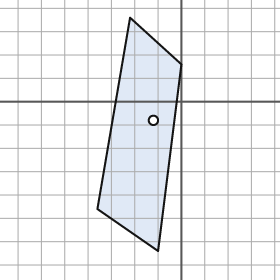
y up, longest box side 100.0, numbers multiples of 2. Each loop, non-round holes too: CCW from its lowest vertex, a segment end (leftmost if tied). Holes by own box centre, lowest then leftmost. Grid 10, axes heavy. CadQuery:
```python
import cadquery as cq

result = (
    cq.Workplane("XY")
    .moveTo(-10.0, -64.0)
    .lineTo(0.0, 16.0)
    .lineTo(-22.0, 36.0)
    .lineTo(-36.0, -46.0)
    .close()
    .moveTo(-12.0, -8.0)
    .circle(2.0)
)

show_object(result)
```